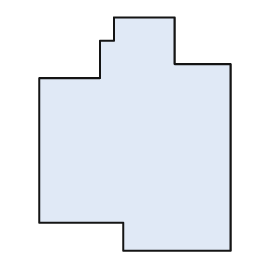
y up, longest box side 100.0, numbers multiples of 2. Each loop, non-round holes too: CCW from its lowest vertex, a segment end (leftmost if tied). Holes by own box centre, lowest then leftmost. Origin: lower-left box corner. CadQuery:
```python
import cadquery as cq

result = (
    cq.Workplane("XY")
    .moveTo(36.0, 0.0)
    .lineTo(82.0, 0.0)
    .lineTo(82.0, 80.0)
    .lineTo(58.0, 80.0)
    .lineTo(58.0, 100.0)
    .lineTo(32.0, 100.0)
    .lineTo(32.0, 90.0)
    .lineTo(26.0, 90.0)
    .lineTo(26.0, 74.0)
    .lineTo(0.0, 74.0)
    .lineTo(0.0, 12.0)
    .lineTo(36.0, 12.0)
    .close()
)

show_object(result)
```